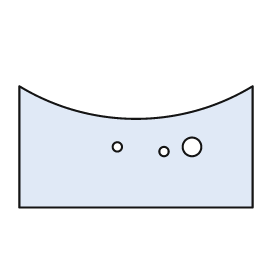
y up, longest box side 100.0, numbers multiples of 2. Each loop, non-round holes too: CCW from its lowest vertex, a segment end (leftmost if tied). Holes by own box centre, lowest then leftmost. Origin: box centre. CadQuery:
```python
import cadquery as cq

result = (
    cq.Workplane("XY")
    .moveTo(-50.0, -26.0)
    .lineTo(50.0, -26.0)
    .lineTo(50.0, 26.0)
    .threePointArc((0.0, 12.0), (-50.0, 26.0))
    .close()
    .moveTo(12.0, -2.0)
    .circle(2.0)
    .moveTo(-8.0, 0.0)
    .circle(2.0)
    .moveTo(24.0, 0.0)
    .circle(4.0)
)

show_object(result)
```